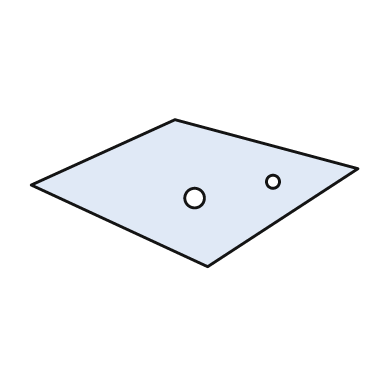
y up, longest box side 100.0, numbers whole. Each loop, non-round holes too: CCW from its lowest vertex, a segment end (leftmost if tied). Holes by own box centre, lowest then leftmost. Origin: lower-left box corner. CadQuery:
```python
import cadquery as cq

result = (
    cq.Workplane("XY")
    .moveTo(54.0, 0.0)
    .lineTo(100.0, 30.0)
    .lineTo(44.0, 45.0)
    .lineTo(0.0, 25.0)
    .close()
    .moveTo(50.0, 21.0)
    .circle(3.0)
    .moveTo(74.0, 26.0)
    .circle(2.0)
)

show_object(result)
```